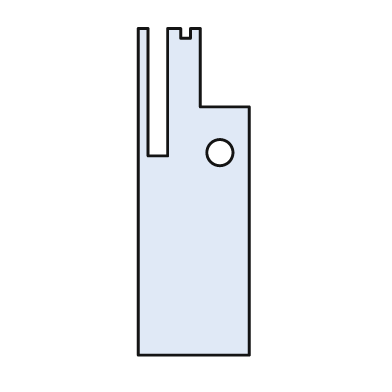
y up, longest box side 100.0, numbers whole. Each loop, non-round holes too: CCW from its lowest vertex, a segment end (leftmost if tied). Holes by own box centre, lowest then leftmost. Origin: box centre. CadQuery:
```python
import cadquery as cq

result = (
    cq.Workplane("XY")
    .moveTo(-17.0, -50.0)
    .lineTo(17.0, -50.0)
    .lineTo(17.0, 26.0)
    .lineTo(2.0, 26.0)
    .lineTo(2.0, 50.0)
    .lineTo(-1.0, 50.0)
    .lineTo(-1.0, 47.0)
    .lineTo(-4.0, 47.0)
    .lineTo(-4.0, 50.0)
    .lineTo(-8.0, 50.0)
    .lineTo(-8.0, 11.0)
    .lineTo(-14.0, 11.0)
    .lineTo(-14.0, 50.0)
    .lineTo(-17.0, 50.0)
    .close()
    .moveTo(8.0, 12.0)
    .circle(4.0)
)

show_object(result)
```